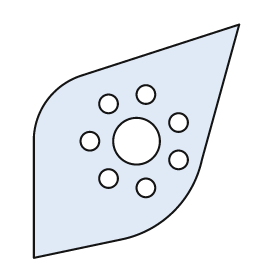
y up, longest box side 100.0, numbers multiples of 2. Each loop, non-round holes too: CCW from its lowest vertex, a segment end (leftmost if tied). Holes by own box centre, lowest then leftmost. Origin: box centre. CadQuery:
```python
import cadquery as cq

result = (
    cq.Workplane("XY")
    .moveTo(-44.0, -50.0)
    .lineTo(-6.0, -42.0)
    .threePointArc((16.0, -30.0), (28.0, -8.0))
    .lineTo(44.0, 50.0)
    .lineTo(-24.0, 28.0)
    .threePointArc((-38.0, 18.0), (-44.0, 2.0))
    .close()
    .moveTo(4.0, -20.0)
    .circle(4.0)
    .moveTo(-12.0, -16.0)
    .circle(4.0)
    .moveTo(18.0, -8.0)
    .circle(4.0)
    .moveTo(-20.0, 0.0)
    .circle(4.0)
    .moveTo(0.0, 0.0)
    .circle(10.0)
    .moveTo(18.0, 8.0)
    .circle(4.0)
    .moveTo(-12.0, 16.0)
    .circle(4.0)
    .moveTo(4.0, 20.0)
    .circle(4.0)
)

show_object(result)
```